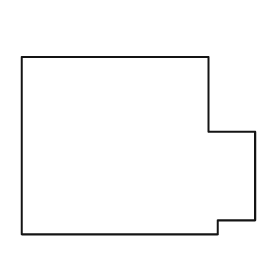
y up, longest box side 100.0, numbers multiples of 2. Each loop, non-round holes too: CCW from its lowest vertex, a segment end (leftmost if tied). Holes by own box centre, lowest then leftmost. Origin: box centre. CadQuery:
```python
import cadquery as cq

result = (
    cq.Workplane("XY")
    .moveTo(-50.0, -38.0)
    .lineTo(34.0, -38.0)
    .lineTo(34.0, -32.0)
    .lineTo(50.0, -32.0)
    .lineTo(50.0, 6.0)
    .lineTo(30.0, 6.0)
    .lineTo(30.0, 38.0)
    .lineTo(-50.0, 38.0)
    .close()
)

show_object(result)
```